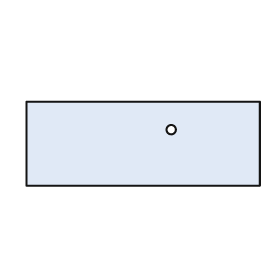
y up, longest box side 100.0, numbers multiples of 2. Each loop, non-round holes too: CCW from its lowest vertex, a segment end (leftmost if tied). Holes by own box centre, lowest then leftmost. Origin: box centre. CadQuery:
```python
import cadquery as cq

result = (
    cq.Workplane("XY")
    .moveTo(-50.0, -18.0)
    .lineTo(50.0, -18.0)
    .lineTo(50.0, 18.0)
    .lineTo(-50.0, 18.0)
    .close()
    .moveTo(12.0, 6.0)
    .circle(2.0)
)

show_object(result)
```